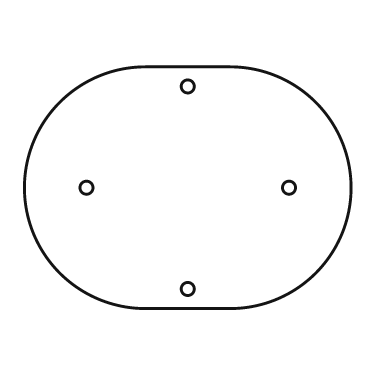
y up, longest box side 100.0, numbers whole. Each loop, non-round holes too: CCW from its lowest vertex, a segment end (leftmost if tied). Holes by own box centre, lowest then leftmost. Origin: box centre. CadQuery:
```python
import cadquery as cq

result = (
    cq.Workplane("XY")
    .moveTo(-13.0, -37.0)
    .lineTo(13.0, -37.0)
    .threePointArc((50.0, 0.0), (13.0, 37.0))
    .lineTo(-13.0, 37.0)
    .threePointArc((-50.0, 0.0), (-13.0, -37.0))
    .close()
    .moveTo(0.0, -31.0)
    .circle(2.0)
    .moveTo(-31.0, 0.0)
    .circle(2.0)
    .moveTo(31.0, 0.0)
    .circle(2.0)
    .moveTo(0.0, 31.0)
    .circle(2.0)
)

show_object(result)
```